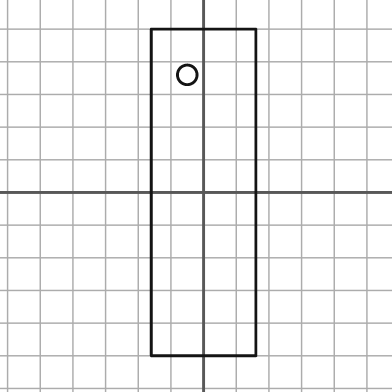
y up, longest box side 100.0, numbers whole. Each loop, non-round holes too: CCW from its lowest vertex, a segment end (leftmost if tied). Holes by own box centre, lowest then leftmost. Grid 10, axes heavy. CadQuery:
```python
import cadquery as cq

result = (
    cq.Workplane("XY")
    .moveTo(-16.0, -50.0)
    .lineTo(16.0, -50.0)
    .lineTo(16.0, 50.0)
    .lineTo(-16.0, 50.0)
    .close()
    .moveTo(-5.0, 36.0)
    .circle(3.0)
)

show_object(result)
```